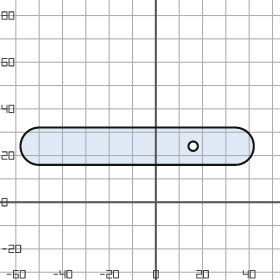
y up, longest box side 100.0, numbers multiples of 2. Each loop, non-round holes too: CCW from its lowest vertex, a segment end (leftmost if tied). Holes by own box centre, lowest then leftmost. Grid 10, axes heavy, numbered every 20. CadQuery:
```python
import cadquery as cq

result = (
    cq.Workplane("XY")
    .moveTo(-50.0, 16.0)
    .lineTo(34.0, 16.0)
    .threePointArc((42.0, 24.0), (34.0, 32.0))
    .lineTo(-50.0, 32.0)
    .threePointArc((-58.0, 24.0), (-50.0, 16.0))
    .close()
    .moveTo(16.0, 24.0)
    .circle(2.0)
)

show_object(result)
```